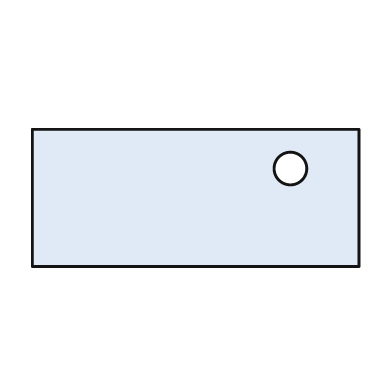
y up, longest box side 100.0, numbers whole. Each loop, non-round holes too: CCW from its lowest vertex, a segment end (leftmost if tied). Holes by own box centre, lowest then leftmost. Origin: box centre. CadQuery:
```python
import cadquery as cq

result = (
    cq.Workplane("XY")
    .moveTo(-50.0, -21.0)
    .lineTo(50.0, -21.0)
    .lineTo(50.0, 21.0)
    .lineTo(-50.0, 21.0)
    .close()
    .moveTo(29.0, 9.0)
    .circle(5.0)
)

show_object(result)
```